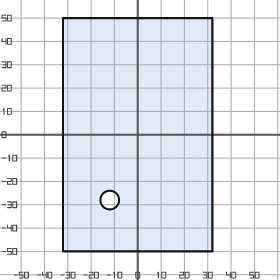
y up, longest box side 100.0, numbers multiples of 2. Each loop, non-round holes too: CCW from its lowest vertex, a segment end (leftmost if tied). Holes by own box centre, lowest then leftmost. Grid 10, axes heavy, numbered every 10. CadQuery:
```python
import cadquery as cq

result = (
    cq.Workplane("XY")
    .moveTo(-32.0, -50.0)
    .lineTo(32.0, -50.0)
    .lineTo(32.0, 50.0)
    .lineTo(-32.0, 50.0)
    .close()
    .moveTo(-12.0, -28.0)
    .circle(4.0)
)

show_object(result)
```